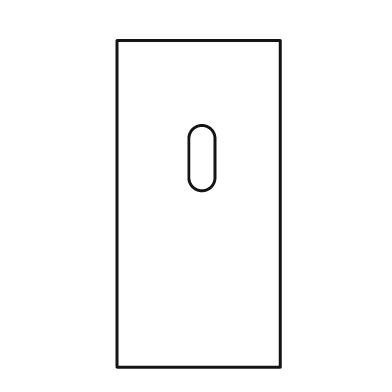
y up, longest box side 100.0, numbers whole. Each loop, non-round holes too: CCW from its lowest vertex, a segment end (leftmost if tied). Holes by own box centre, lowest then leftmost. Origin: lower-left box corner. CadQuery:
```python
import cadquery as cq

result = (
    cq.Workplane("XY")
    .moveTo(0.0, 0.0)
    .lineTo(50.0, 0.0)
    .lineTo(50.0, 100.0)
    .lineTo(0.0, 100.0)
    .close()
    .moveTo(22.0, 58.0)
    .threePointArc((26.0, 54.0), (30.0, 58.0))
    .lineTo(30.0, 70.0)
    .threePointArc((26.0, 74.0), (22.0, 70.0))
    .close()
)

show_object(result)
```